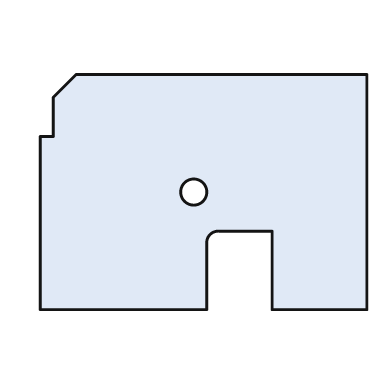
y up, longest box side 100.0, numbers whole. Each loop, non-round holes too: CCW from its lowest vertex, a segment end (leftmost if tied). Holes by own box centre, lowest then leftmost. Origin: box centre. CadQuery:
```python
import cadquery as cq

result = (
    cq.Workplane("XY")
    .moveTo(-50.0, -36.0)
    .lineTo(1.0, -36.0)
    .lineTo(1.0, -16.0)
    .threePointArc((2.0, -13.0), (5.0, -12.0))
    .lineTo(21.0, -12.0)
    .lineTo(21.0, -36.0)
    .lineTo(50.0, -36.0)
    .lineTo(50.0, 36.0)
    .lineTo(-39.0, 36.0)
    .lineTo(-46.0, 29.0)
    .lineTo(-46.0, 17.0)
    .lineTo(-50.0, 17.0)
    .close()
    .moveTo(-3.0, 0.0)
    .circle(4.0)
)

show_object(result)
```